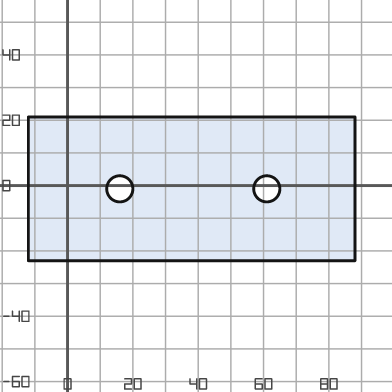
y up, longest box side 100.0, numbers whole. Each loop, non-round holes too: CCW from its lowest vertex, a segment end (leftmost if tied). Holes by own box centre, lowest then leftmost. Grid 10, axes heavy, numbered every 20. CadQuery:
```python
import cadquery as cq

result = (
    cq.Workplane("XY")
    .moveTo(-12.0, -23.0)
    .lineTo(88.0, -23.0)
    .lineTo(88.0, 21.0)
    .lineTo(-12.0, 21.0)
    .close()
    .moveTo(16.0, -1.0)
    .circle(4.0)
    .moveTo(61.0, -1.0)
    .circle(4.0)
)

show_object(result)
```